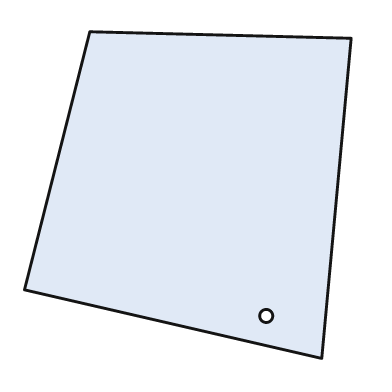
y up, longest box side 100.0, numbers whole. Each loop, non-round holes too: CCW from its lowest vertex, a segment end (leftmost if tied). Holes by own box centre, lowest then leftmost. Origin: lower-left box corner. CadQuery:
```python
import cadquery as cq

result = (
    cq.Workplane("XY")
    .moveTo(91.0, 0.0)
    .lineTo(100.0, 98.0)
    .lineTo(20.0, 100.0)
    .lineTo(0.0, 21.0)
    .close()
    .moveTo(74.0, 13.0)
    .circle(2.0)
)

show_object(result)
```